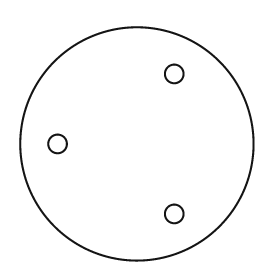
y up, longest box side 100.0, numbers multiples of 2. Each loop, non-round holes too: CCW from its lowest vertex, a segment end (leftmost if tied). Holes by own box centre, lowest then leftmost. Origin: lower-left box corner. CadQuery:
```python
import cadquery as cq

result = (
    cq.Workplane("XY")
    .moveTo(50.0, 50.0)
    .circle(50.0)
    .moveTo(66.0, 20.0)
    .circle(4.0)
    .moveTo(16.0, 50.0)
    .circle(4.0)
    .moveTo(66.0, 80.0)
    .circle(4.0)
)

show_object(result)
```